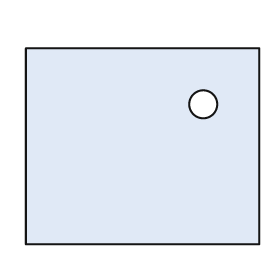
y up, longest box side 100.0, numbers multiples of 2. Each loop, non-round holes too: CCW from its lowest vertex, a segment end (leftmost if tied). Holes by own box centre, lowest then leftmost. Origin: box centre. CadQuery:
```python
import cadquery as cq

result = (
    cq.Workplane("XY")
    .moveTo(-50.0, -42.0)
    .lineTo(50.0, -42.0)
    .lineTo(50.0, 42.0)
    .lineTo(-50.0, 42.0)
    .close()
    .moveTo(26.0, 18.0)
    .circle(6.0)
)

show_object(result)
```